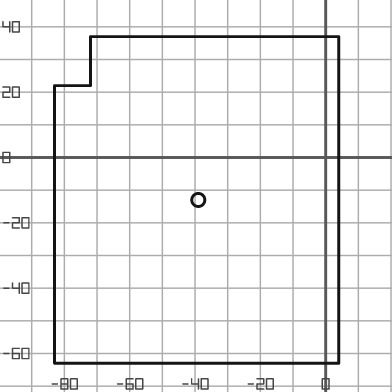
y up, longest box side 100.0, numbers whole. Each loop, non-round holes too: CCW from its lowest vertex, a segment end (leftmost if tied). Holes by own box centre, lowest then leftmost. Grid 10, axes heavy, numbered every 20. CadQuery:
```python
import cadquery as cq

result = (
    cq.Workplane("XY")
    .moveTo(-83.0, -63.0)
    .lineTo(4.0, -63.0)
    .lineTo(4.0, 37.0)
    .lineTo(-72.0, 37.0)
    .lineTo(-72.0, 22.0)
    .lineTo(-83.0, 22.0)
    .close()
    .moveTo(-39.0, -13.0)
    .circle(2.0)
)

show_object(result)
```